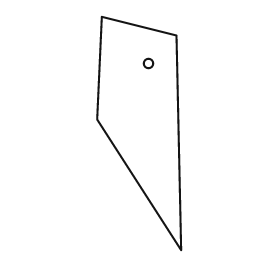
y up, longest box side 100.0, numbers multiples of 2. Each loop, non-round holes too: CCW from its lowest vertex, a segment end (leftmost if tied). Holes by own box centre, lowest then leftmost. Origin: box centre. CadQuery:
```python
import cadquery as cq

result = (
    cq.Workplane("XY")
    .moveTo(18.0, -50.0)
    .lineTo(16.0, 42.0)
    .lineTo(-16.0, 50.0)
    .lineTo(-18.0, 6.0)
    .close()
    .moveTo(4.0, 30.0)
    .circle(2.0)
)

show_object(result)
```